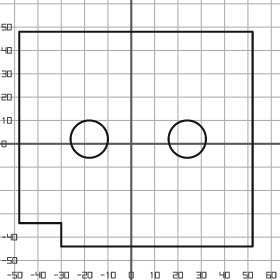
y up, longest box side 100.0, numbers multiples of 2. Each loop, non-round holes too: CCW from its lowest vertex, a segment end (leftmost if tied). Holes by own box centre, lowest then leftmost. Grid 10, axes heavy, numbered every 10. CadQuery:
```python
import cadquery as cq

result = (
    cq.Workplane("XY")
    .moveTo(-30.0, -44.0)
    .lineTo(52.0, -44.0)
    .lineTo(52.0, 48.0)
    .lineTo(-48.0, 48.0)
    .lineTo(-48.0, -34.0)
    .lineTo(-30.0, -34.0)
    .close()
    .moveTo(-18.0, 2.0)
    .circle(8.0)
    .moveTo(24.0, 2.0)
    .circle(8.0)
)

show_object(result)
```